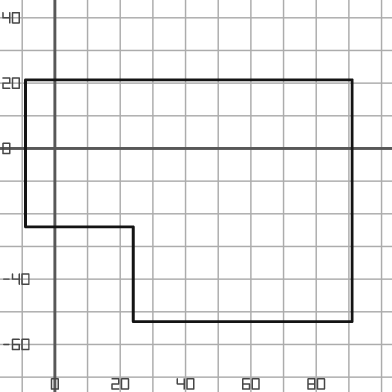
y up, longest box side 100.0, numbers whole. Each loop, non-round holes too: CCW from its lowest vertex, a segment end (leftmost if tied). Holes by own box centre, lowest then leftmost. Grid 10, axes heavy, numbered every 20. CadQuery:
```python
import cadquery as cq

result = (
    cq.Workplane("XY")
    .moveTo(24.0, -53.0)
    .lineTo(91.0, -53.0)
    .lineTo(91.0, 21.0)
    .lineTo(-9.0, 21.0)
    .lineTo(-9.0, -24.0)
    .lineTo(24.0, -24.0)
    .close()
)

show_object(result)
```